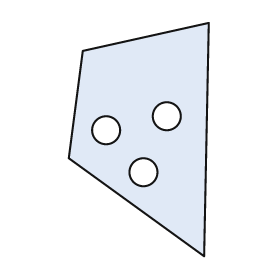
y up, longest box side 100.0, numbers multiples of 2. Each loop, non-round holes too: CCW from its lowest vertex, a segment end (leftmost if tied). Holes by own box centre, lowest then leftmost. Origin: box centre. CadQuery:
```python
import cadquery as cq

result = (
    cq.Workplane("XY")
    .moveTo(28.0, -50.0)
    .lineTo(30.0, 50.0)
    .lineTo(-24.0, 38.0)
    .lineTo(-30.0, -8.0)
    .close()
    .moveTo(2.0, -14.0)
    .circle(6.0)
    .moveTo(-14.0, 4.0)
    .circle(6.0)
    .moveTo(12.0, 10.0)
    .circle(6.0)
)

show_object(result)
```